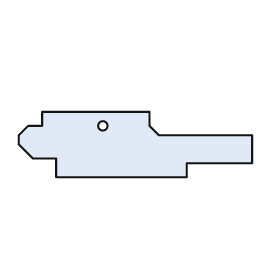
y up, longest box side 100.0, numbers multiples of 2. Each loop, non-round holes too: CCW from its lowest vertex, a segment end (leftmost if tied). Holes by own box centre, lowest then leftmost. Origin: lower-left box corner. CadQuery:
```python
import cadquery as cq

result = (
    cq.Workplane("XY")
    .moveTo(16.0, 0.0)
    .lineTo(72.0, 0.0)
    .lineTo(72.0, 6.0)
    .lineTo(100.0, 6.0)
    .lineTo(100.0, 18.0)
    .lineTo(60.0, 18.0)
    .lineTo(56.0, 22.0)
    .lineTo(56.0, 28.0)
    .lineTo(10.0, 28.0)
    .lineTo(10.0, 22.0)
    .lineTo(4.0, 22.0)
    .lineTo(0.0, 18.0)
    .lineTo(0.0, 14.0)
    .lineTo(6.0, 8.0)
    .lineTo(16.0, 8.0)
    .close()
    .moveTo(36.0, 22.0)
    .circle(2.0)
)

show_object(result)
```